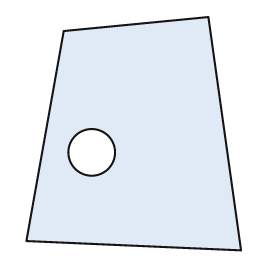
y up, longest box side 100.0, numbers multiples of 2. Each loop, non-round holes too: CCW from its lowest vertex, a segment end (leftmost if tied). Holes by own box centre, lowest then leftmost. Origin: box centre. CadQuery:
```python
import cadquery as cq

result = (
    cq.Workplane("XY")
    .moveTo(46.0, -50.0)
    .lineTo(32.0, 50.0)
    .lineTo(-30.0, 44.0)
    .lineTo(-46.0, -46.0)
    .close()
    .moveTo(-18.0, -8.0)
    .circle(10.0)
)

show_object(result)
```